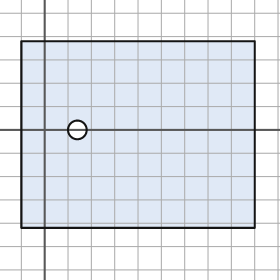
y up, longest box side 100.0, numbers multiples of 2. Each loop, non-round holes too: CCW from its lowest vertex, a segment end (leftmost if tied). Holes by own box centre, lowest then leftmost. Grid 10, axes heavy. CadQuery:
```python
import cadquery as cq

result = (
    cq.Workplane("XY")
    .moveTo(-10.0, -42.0)
    .lineTo(90.0, -42.0)
    .lineTo(90.0, 38.0)
    .lineTo(-10.0, 38.0)
    .close()
    .moveTo(14.0, 0.0)
    .circle(4.0)
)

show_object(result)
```